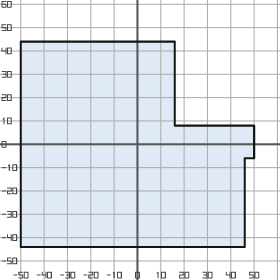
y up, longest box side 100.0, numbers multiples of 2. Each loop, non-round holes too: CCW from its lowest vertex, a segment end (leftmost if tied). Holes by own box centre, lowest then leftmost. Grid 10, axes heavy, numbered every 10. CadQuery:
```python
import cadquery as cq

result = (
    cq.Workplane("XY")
    .moveTo(-50.0, -44.0)
    .lineTo(46.0, -44.0)
    .lineTo(46.0, -6.0)
    .lineTo(50.0, -6.0)
    .lineTo(50.0, 8.0)
    .lineTo(16.0, 8.0)
    .lineTo(16.0, 44.0)
    .lineTo(-50.0, 44.0)
    .close()
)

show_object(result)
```